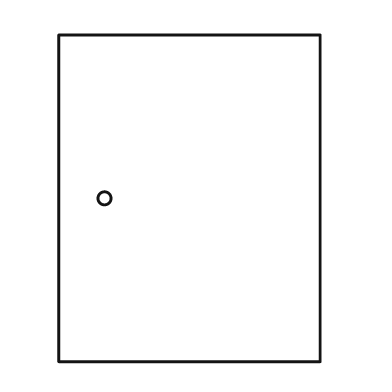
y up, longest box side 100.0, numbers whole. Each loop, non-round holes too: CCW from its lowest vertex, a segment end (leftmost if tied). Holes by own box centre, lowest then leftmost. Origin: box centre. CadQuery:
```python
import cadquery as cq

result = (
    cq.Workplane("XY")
    .moveTo(-40.0, -50.0)
    .lineTo(40.0, -50.0)
    .lineTo(40.0, 50.0)
    .lineTo(-40.0, 50.0)
    .close()
    .moveTo(-26.0, 0.0)
    .circle(2.0)
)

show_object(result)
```